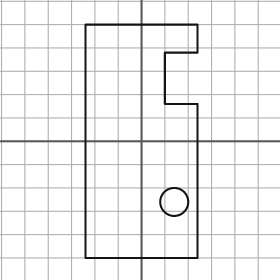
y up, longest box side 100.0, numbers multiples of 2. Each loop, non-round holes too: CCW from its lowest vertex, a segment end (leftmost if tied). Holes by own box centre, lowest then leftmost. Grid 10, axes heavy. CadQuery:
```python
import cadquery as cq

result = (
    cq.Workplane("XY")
    .moveTo(-24.0, -50.0)
    .lineTo(24.0, -50.0)
    .lineTo(24.0, 16.0)
    .lineTo(10.0, 16.0)
    .lineTo(10.0, 38.0)
    .lineTo(24.0, 38.0)
    .lineTo(24.0, 50.0)
    .lineTo(-24.0, 50.0)
    .close()
    .moveTo(14.0, -26.0)
    .circle(6.0)
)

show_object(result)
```